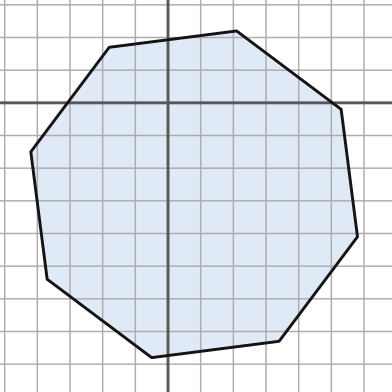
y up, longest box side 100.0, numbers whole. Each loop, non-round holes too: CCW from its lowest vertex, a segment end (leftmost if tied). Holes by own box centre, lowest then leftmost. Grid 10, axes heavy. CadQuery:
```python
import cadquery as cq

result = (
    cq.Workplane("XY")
    .moveTo(-5.0, -78.0)
    .lineTo(34.0, -73.0)
    .lineTo(58.0, -41.0)
    .lineTo(53.0, -2.0)
    .lineTo(21.0, 22.0)
    .lineTo(-18.0, 17.0)
    .lineTo(-42.0, -15.0)
    .lineTo(-37.0, -54.0)
    .close()
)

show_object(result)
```